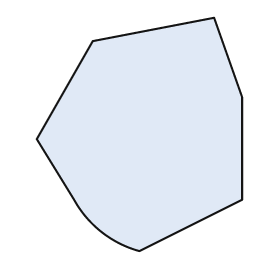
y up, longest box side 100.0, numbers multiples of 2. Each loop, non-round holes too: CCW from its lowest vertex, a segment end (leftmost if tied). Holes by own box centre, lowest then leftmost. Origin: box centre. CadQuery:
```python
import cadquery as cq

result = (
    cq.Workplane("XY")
    .moveTo(0.0, -50.0)
    .lineTo(44.0, -28.0)
    .lineTo(44.0, 16.0)
    .lineTo(32.0, 50.0)
    .lineTo(-20.0, 40.0)
    .lineTo(-44.0, -2.0)
    .lineTo(-28.0, -28.0)
    .threePointArc((-16.0, -42.0), (0.0, -50.0))
    .close()
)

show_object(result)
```